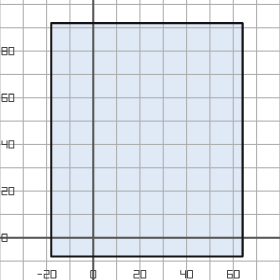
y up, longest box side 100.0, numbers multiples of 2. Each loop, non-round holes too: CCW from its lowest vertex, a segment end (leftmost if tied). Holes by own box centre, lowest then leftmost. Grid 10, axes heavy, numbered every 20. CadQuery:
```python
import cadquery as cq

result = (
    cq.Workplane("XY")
    .moveTo(-18.0, -8.0)
    .lineTo(64.0, -8.0)
    .lineTo(64.0, 92.0)
    .lineTo(-18.0, 92.0)
    .close()
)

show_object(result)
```